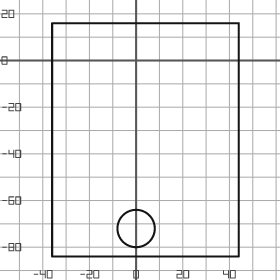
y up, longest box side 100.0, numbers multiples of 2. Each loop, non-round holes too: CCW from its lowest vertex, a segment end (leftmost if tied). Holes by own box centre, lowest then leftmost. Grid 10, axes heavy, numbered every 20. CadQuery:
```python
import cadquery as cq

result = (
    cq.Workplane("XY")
    .moveTo(-36.0, -84.0)
    .lineTo(44.0, -84.0)
    .lineTo(44.0, 16.0)
    .lineTo(-36.0, 16.0)
    .close()
    .moveTo(0.0, -72.0)
    .circle(8.0)
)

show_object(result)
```